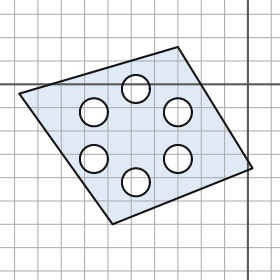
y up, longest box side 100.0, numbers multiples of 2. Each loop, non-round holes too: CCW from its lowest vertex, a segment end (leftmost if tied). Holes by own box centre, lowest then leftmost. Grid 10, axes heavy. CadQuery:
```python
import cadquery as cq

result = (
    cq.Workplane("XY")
    .moveTo(-58.0, -60.0)
    .lineTo(2.0, -36.0)
    .lineTo(-30.0, 16.0)
    .lineTo(-98.0, -4.0)
    .close()
    .moveTo(-48.0, -42.0)
    .circle(6.0)
    .moveTo(-66.0, -32.0)
    .circle(6.0)
    .moveTo(-30.0, -32.0)
    .circle(6.0)
    .moveTo(-66.0, -12.0)
    .circle(6.0)
    .moveTo(-30.0, -12.0)
    .circle(6.0)
    .moveTo(-48.0, -2.0)
    .circle(6.0)
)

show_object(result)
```